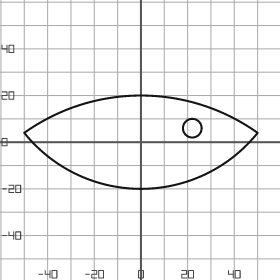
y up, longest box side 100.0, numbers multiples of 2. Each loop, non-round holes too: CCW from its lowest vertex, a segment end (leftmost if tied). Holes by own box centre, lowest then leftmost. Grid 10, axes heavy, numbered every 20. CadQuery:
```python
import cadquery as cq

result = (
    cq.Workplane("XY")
    .moveTo(-50.0, 4.0)
    .threePointArc((0.0, -20.0), (50.0, 4.0))
    .threePointArc((0.0, 20.0), (-50.0, 4.0))
    .close()
    .moveTo(22.0, 6.0)
    .circle(4.0)
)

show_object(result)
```